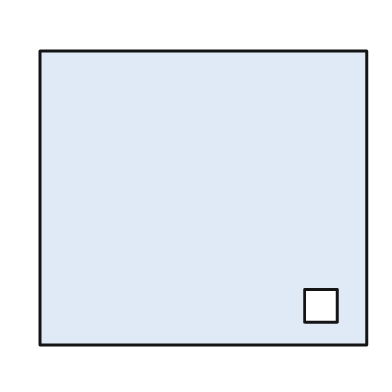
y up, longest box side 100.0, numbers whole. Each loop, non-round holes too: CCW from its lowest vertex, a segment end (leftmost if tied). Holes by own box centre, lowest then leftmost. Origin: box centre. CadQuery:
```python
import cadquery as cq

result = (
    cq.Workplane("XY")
    .moveTo(-50.0, -45.0)
    .lineTo(50.0, -45.0)
    .lineTo(50.0, 45.0)
    .lineTo(-50.0, 45.0)
    .close()
    .moveTo(31.0, -38.0)
    .lineTo(41.0, -38.0)
    .lineTo(41.0, -28.0)
    .lineTo(31.0, -28.0)
    .close()
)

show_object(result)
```